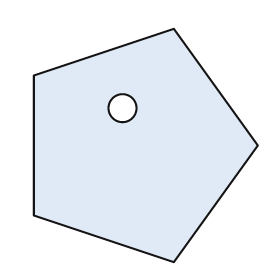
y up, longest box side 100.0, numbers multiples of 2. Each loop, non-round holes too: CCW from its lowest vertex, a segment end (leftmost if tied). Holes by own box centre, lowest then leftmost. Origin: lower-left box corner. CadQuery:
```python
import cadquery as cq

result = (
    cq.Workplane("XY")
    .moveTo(60.0, 0.0)
    .lineTo(96.0, 50.0)
    .lineTo(60.0, 100.0)
    .lineTo(0.0, 80.0)
    .lineTo(0.0, 20.0)
    .close()
    .moveTo(38.0, 66.0)
    .circle(6.0)
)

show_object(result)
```